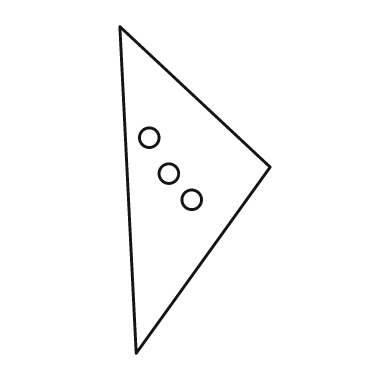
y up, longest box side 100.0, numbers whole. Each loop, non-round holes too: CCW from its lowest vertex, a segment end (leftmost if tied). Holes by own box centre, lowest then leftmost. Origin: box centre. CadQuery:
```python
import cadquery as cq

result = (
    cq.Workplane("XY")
    .moveTo(-18.0, -50.0)
    .lineTo(23.0, 7.0)
    .lineTo(-23.0, 50.0)
    .close()
    .moveTo(-1.0, -3.0)
    .circle(3.0)
    .moveTo(-8.0, 5.0)
    .circle(3.0)
    .moveTo(-14.0, 16.0)
    .circle(3.0)
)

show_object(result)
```